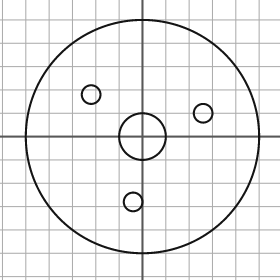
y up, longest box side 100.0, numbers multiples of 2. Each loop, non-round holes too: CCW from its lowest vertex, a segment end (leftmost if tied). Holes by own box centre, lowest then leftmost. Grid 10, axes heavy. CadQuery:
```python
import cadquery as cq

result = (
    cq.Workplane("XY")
    .moveTo(0.0, 0.0)
    .circle(50.0)
    .moveTo(-4.0, -28.0)
    .circle(4.0)
    .moveTo(0.0, 0.0)
    .circle(10.0)
    .moveTo(26.0, 10.0)
    .circle(4.0)
    .moveTo(-22.0, 18.0)
    .circle(4.0)
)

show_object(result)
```